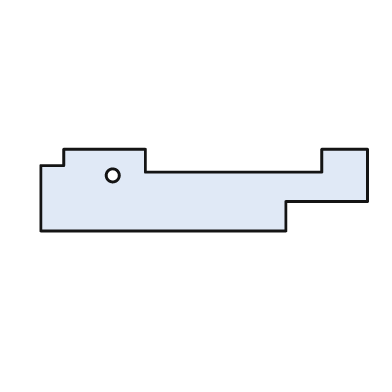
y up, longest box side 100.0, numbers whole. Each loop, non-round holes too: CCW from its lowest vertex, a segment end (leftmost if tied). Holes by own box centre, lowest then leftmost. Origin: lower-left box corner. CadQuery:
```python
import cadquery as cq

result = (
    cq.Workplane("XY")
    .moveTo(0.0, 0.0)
    .lineTo(75.0, 0.0)
    .lineTo(75.0, 9.0)
    .lineTo(100.0, 9.0)
    .lineTo(100.0, 25.0)
    .lineTo(86.0, 25.0)
    .lineTo(86.0, 18.0)
    .lineTo(32.0, 18.0)
    .lineTo(32.0, 25.0)
    .lineTo(7.0, 25.0)
    .lineTo(7.0, 20.0)
    .lineTo(0.0, 20.0)
    .close()
    .moveTo(22.0, 17.0)
    .circle(2.0)
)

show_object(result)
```